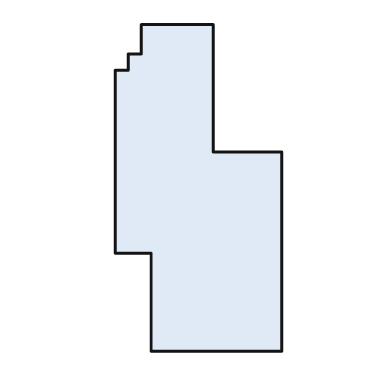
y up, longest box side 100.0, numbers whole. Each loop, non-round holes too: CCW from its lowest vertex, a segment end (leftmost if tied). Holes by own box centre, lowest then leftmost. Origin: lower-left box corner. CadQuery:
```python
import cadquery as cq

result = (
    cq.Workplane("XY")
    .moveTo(11.0, 0.0)
    .lineTo(51.0, 0.0)
    .lineTo(51.0, 61.0)
    .lineTo(30.0, 61.0)
    .lineTo(30.0, 100.0)
    .lineTo(8.0, 100.0)
    .lineTo(8.0, 91.0)
    .lineTo(4.0, 91.0)
    .lineTo(4.0, 86.0)
    .lineTo(0.0, 86.0)
    .lineTo(0.0, 30.0)
    .lineTo(11.0, 30.0)
    .close()
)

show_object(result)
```